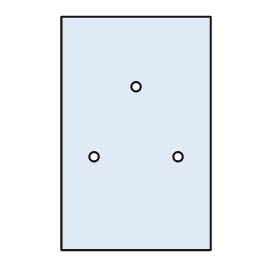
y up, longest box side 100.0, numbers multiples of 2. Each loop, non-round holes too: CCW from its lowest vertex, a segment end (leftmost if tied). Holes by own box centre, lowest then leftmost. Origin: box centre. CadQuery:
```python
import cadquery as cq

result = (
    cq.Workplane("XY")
    .moveTo(-32.0, -50.0)
    .lineTo(32.0, -50.0)
    .lineTo(32.0, 50.0)
    .lineTo(-32.0, 50.0)
    .close()
    .moveTo(-18.0, -10.0)
    .circle(2.0)
    .moveTo(18.0, -10.0)
    .circle(2.0)
    .moveTo(0.0, 20.0)
    .circle(2.0)
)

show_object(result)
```